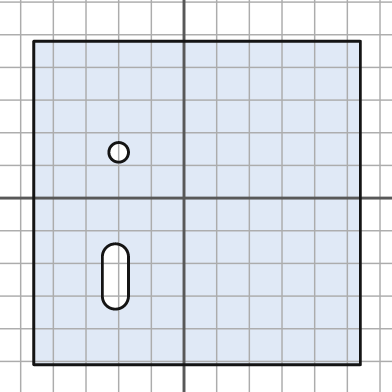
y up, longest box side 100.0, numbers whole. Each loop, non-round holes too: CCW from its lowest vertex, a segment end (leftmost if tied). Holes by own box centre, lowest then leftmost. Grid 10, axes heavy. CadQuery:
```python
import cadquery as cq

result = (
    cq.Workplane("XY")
    .moveTo(-46.0, -51.0)
    .lineTo(54.0, -51.0)
    .lineTo(54.0, 48.0)
    .lineTo(-46.0, 48.0)
    .close()
    .moveTo(-25.0, -30.0)
    .threePointArc((-21.0, -34.0), (-17.0, -30.0))
    .lineTo(-17.0, -18.0)
    .threePointArc((-21.0, -14.0), (-25.0, -18.0))
    .close()
    .moveTo(-20.0, 14.0)
    .circle(3.0)
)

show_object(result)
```